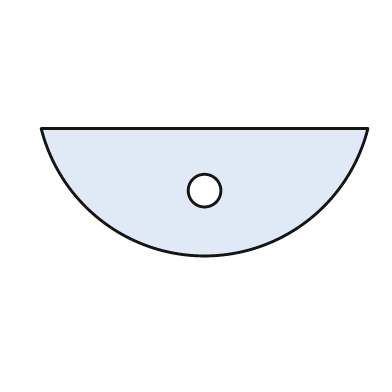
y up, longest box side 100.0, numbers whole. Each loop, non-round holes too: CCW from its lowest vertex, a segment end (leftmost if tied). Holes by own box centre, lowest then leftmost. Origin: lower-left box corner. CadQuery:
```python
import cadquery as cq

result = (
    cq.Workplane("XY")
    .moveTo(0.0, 39.0)
    .threePointArc((50.0, 0.0), (100.0, 39.0))
    .close()
    .moveTo(50.0, 20.0)
    .circle(5.0)
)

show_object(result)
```